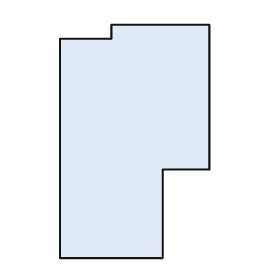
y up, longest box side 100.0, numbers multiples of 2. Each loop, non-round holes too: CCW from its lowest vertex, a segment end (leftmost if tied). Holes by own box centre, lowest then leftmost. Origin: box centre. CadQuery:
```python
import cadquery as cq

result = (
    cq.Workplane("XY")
    .moveTo(-32.0, -50.0)
    .lineTo(12.0, -50.0)
    .lineTo(12.0, -12.0)
    .lineTo(32.0, -12.0)
    .lineTo(32.0, 50.0)
    .lineTo(-10.0, 50.0)
    .lineTo(-10.0, 44.0)
    .lineTo(-32.0, 44.0)
    .close()
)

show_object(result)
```